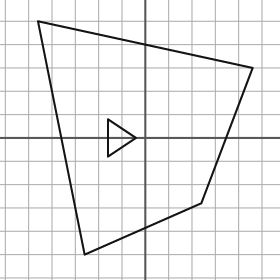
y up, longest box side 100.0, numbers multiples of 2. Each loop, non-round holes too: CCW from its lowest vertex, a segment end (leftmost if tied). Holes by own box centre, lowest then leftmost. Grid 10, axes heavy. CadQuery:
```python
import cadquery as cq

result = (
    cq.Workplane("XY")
    .moveTo(-26.0, -50.0)
    .lineTo(24.0, -28.0)
    .lineTo(46.0, 30.0)
    .lineTo(-46.0, 50.0)
    .close()
    .moveTo(-16.0, -8.0)
    .lineTo(-4.0, 0.0)
    .lineTo(-16.0, 8.0)
    .close()
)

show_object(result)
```